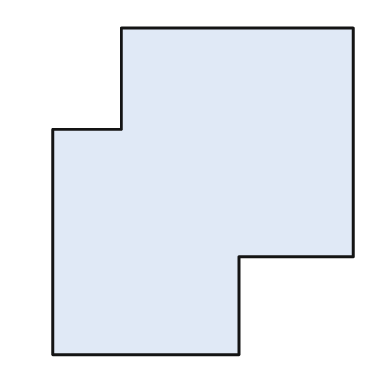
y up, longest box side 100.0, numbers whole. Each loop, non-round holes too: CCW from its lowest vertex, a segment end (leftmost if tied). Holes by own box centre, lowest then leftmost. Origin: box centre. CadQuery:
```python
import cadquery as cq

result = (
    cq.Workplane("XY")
    .moveTo(-46.0, -50.0)
    .lineTo(11.0, -50.0)
    .lineTo(11.0, -20.0)
    .lineTo(46.0, -20.0)
    .lineTo(46.0, 50.0)
    .lineTo(-25.0, 50.0)
    .lineTo(-25.0, 19.0)
    .lineTo(-46.0, 19.0)
    .close()
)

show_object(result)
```